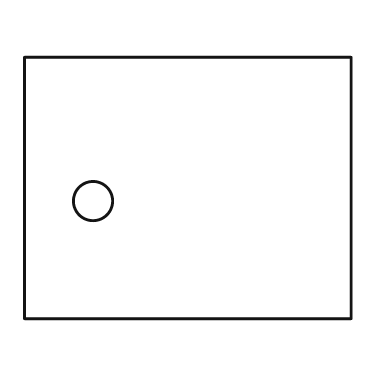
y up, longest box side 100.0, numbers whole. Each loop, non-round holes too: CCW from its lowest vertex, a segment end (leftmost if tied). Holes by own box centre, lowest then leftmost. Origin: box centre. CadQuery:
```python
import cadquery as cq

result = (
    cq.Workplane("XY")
    .moveTo(-50.0, -40.0)
    .lineTo(50.0, -40.0)
    .lineTo(50.0, 40.0)
    .lineTo(-50.0, 40.0)
    .close()
    .moveTo(-29.0, -4.0)
    .circle(6.0)
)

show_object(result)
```